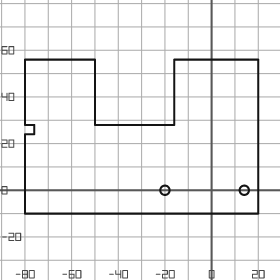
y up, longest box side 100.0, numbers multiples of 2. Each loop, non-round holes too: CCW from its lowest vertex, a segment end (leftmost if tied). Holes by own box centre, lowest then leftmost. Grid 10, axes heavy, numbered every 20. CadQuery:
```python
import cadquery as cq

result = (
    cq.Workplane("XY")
    .moveTo(-80.0, -10.0)
    .lineTo(20.0, -10.0)
    .lineTo(20.0, 56.0)
    .lineTo(-16.0, 56.0)
    .lineTo(-16.0, 28.0)
    .lineTo(-50.0, 28.0)
    .lineTo(-50.0, 56.0)
    .lineTo(-80.0, 56.0)
    .lineTo(-80.0, 28.0)
    .lineTo(-76.0, 28.0)
    .lineTo(-76.0, 24.0)
    .lineTo(-80.0, 24.0)
    .close()
    .moveTo(-20.0, 0.0)
    .circle(2.0)
    .moveTo(14.0, 0.0)
    .circle(2.0)
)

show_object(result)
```